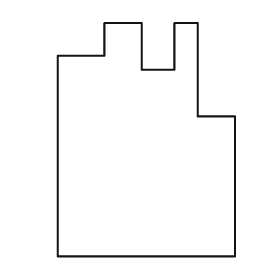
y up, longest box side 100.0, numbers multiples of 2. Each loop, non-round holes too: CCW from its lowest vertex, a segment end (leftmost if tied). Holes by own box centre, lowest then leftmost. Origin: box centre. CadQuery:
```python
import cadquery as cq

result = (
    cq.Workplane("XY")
    .moveTo(-38.0, -50.0)
    .lineTo(38.0, -50.0)
    .lineTo(38.0, 10.0)
    .lineTo(22.0, 10.0)
    .lineTo(22.0, 50.0)
    .lineTo(12.0, 50.0)
    .lineTo(12.0, 30.0)
    .lineTo(-2.0, 30.0)
    .lineTo(-2.0, 50.0)
    .lineTo(-18.0, 50.0)
    .lineTo(-18.0, 36.0)
    .lineTo(-38.0, 36.0)
    .close()
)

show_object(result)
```